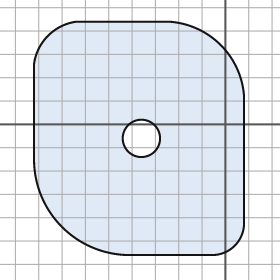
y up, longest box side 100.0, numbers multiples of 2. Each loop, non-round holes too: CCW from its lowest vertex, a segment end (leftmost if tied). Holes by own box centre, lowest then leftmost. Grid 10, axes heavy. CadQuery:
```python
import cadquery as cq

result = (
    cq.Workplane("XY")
    .moveTo(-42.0, -56.0)
    .lineTo(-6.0, -56.0)
    .threePointArc((4.0, -52.0), (8.0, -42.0))
    .lineTo(8.0, 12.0)
    .threePointArc((-2.0, 34.0), (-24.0, 44.0))
    .lineTo(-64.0, 44.0)
    .threePointArc((-76.0, 38.0), (-82.0, 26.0))
    .lineTo(-82.0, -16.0)
    .threePointArc((-70.0, -44.0), (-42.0, -56.0))
    .close()
    .moveTo(-36.0, -6.0)
    .circle(8.0)
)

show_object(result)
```